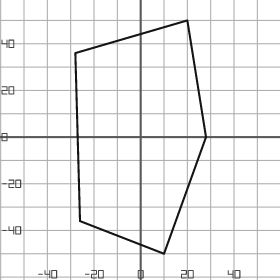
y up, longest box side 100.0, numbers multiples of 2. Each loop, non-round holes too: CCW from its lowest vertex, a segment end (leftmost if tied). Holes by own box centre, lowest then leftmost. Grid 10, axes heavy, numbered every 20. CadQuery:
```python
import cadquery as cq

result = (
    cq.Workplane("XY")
    .moveTo(10.0, -50.0)
    .lineTo(28.0, 0.0)
    .lineTo(20.0, 50.0)
    .lineTo(-28.0, 36.0)
    .lineTo(-26.0, -36.0)
    .close()
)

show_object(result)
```